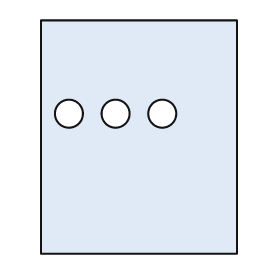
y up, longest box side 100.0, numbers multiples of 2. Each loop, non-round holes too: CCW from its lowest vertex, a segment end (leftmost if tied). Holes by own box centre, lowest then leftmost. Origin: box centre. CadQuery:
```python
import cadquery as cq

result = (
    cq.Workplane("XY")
    .moveTo(-42.0, -50.0)
    .lineTo(42.0, -50.0)
    .lineTo(42.0, 50.0)
    .lineTo(-42.0, 50.0)
    .close()
    .moveTo(-30.0, 10.0)
    .circle(6.0)
    .moveTo(-10.0, 10.0)
    .circle(6.0)
    .moveTo(10.0, 10.0)
    .circle(6.0)
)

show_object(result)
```